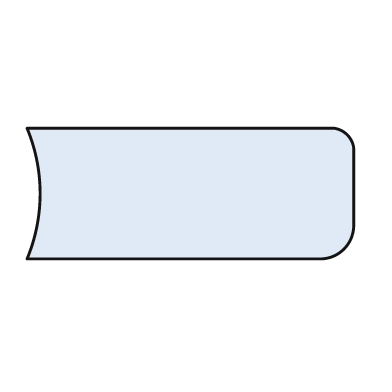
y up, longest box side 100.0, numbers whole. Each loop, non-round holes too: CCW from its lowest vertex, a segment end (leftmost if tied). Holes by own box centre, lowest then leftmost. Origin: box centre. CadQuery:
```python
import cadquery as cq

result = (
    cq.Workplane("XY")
    .moveTo(-50.0, -20.0)
    .lineTo(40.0, -20.0)
    .threePointArc((47.0, -17.0), (50.0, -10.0))
    .lineTo(50.0, 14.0)
    .threePointArc((48.0, 18.0), (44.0, 20.0))
    .lineTo(-50.0, 20.0)
    .threePointArc((-46.0, 0.0), (-50.0, -20.0))
    .close()
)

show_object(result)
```